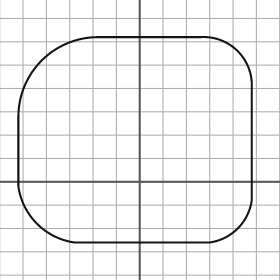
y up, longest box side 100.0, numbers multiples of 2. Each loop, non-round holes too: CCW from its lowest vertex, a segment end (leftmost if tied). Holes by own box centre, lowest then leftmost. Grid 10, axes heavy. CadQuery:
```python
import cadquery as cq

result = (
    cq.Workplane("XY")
    .moveTo(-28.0, -26.0)
    .lineTo(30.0, -26.0)
    .threePointArc((42.0, -20.0), (48.0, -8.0))
    .lineTo(48.0, 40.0)
    .threePointArc((42.0, 56.0), (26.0, 62.0))
    .lineTo(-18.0, 62.0)
    .threePointArc((-42.0, 52.0), (-52.0, 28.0))
    .lineTo(-52.0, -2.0)
    .threePointArc((-44.0, -18.0), (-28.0, -26.0))
    .close()
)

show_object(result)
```